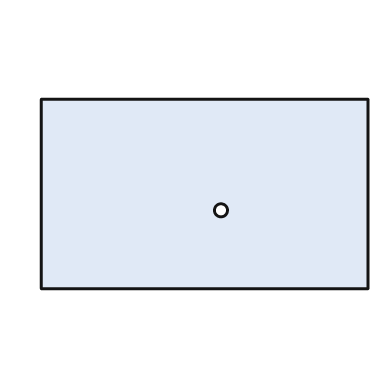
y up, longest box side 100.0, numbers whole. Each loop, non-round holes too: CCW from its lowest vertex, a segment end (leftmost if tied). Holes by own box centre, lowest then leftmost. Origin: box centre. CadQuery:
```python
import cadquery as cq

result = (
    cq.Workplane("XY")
    .moveTo(-50.0, -29.0)
    .lineTo(50.0, -29.0)
    .lineTo(50.0, 29.0)
    .lineTo(-50.0, 29.0)
    .close()
    .moveTo(5.0, -5.0)
    .circle(2.0)
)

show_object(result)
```